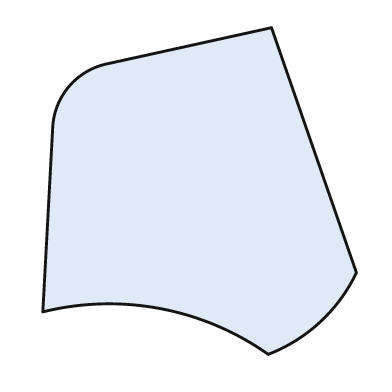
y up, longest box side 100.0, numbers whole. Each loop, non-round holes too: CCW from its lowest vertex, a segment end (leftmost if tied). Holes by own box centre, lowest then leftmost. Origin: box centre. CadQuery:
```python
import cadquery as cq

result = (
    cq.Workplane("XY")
    .moveTo(21.0, -50.0)
    .threePointArc((37.0, -40.0), (48.0, -25.0))
    .lineTo(22.0, 50.0)
    .lineTo(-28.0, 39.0)
    .threePointArc((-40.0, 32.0), (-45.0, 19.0))
    .lineTo(-48.0, -37.0)
    .threePointArc((-12.0, -36.0), (21.0, -50.0))
    .close()
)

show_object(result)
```